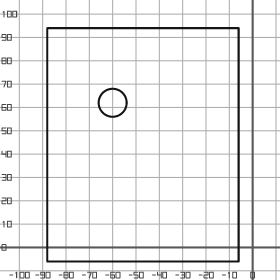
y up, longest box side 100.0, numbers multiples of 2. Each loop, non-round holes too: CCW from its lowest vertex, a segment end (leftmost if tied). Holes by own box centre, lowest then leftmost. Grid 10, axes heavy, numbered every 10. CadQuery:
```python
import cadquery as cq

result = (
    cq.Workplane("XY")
    .moveTo(-88.0, -6.0)
    .lineTo(-6.0, -6.0)
    .lineTo(-6.0, 94.0)
    .lineTo(-88.0, 94.0)
    .close()
    .moveTo(-60.0, 62.0)
    .circle(6.0)
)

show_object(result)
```